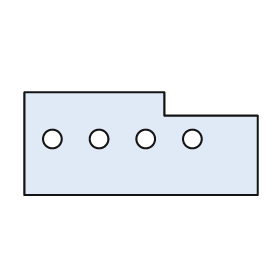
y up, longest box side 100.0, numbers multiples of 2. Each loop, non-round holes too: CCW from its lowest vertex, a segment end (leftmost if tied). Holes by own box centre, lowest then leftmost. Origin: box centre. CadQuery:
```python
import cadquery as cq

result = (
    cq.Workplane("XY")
    .moveTo(-50.0, -22.0)
    .lineTo(50.0, -22.0)
    .lineTo(50.0, 12.0)
    .lineTo(10.0, 12.0)
    .lineTo(10.0, 22.0)
    .lineTo(-50.0, 22.0)
    .close()
    .moveTo(-38.0, 2.0)
    .circle(4.0)
    .moveTo(-18.0, 2.0)
    .circle(4.0)
    .moveTo(2.0, 2.0)
    .circle(4.0)
    .moveTo(22.0, 2.0)
    .circle(4.0)
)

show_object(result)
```